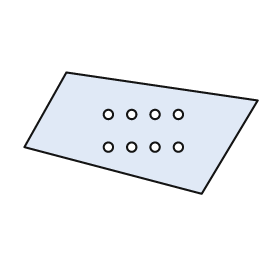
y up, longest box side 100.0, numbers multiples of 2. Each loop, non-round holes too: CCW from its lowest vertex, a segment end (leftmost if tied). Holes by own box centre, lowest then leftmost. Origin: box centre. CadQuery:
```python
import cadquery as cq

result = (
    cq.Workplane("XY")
    .moveTo(26.0, -26.0)
    .lineTo(50.0, 14.0)
    .lineTo(-32.0, 26.0)
    .lineTo(-50.0, -6.0)
    .close()
    .moveTo(-14.0, -6.0)
    .circle(2.0)
    .moveTo(-4.0, -6.0)
    .circle(2.0)
    .moveTo(6.0, -6.0)
    .circle(2.0)
    .moveTo(16.0, -6.0)
    .circle(2.0)
    .moveTo(-14.0, 8.0)
    .circle(2.0)
    .moveTo(-4.0, 8.0)
    .circle(2.0)
    .moveTo(6.0, 8.0)
    .circle(2.0)
    .moveTo(16.0, 8.0)
    .circle(2.0)
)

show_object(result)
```